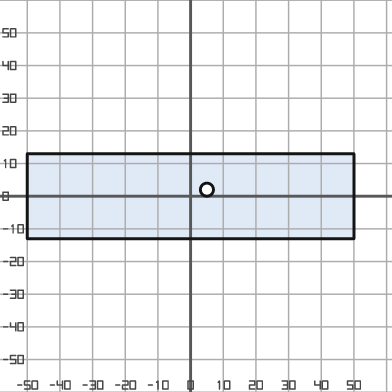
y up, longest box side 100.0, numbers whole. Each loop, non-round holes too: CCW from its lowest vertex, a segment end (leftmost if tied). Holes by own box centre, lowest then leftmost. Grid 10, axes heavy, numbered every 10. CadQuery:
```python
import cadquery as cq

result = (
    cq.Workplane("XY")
    .moveTo(-50.0, -13.0)
    .lineTo(50.0, -13.0)
    .lineTo(50.0, 13.0)
    .lineTo(-50.0, 13.0)
    .close()
    .moveTo(5.0, 2.0)
    .circle(2.0)
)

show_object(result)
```